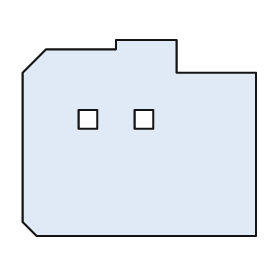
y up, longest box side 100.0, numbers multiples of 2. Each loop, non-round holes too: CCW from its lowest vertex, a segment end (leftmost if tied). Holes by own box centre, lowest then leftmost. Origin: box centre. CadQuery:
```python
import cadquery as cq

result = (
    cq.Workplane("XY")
    .moveTo(-44.0, -42.0)
    .lineTo(50.0, -42.0)
    .lineTo(50.0, 28.0)
    .lineTo(16.0, 28.0)
    .lineTo(16.0, 42.0)
    .lineTo(-10.0, 42.0)
    .lineTo(-10.0, 38.0)
    .lineTo(-40.0, 38.0)
    .lineTo(-50.0, 28.0)
    .lineTo(-50.0, -36.0)
    .close()
    .moveTo(-26.0, 4.0)
    .lineTo(-18.0, 4.0)
    .lineTo(-18.0, 12.0)
    .lineTo(-26.0, 12.0)
    .close()
    .moveTo(-2.0, 4.0)
    .lineTo(6.0, 4.0)
    .lineTo(6.0, 12.0)
    .lineTo(-2.0, 12.0)
    .close()
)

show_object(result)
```